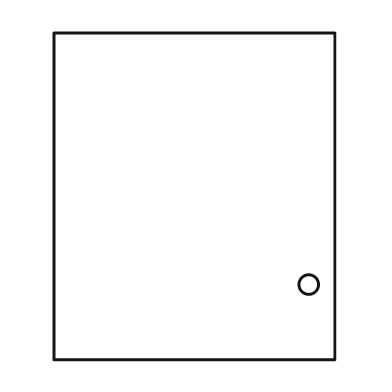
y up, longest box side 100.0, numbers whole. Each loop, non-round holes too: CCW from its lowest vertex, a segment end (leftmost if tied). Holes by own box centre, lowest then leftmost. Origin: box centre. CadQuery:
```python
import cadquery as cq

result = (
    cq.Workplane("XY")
    .moveTo(-43.0, -50.0)
    .lineTo(43.0, -50.0)
    .lineTo(43.0, 50.0)
    .lineTo(-43.0, 50.0)
    .close()
    .moveTo(35.0, -27.0)
    .circle(3.0)
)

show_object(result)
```